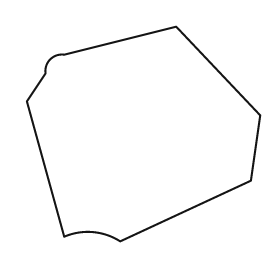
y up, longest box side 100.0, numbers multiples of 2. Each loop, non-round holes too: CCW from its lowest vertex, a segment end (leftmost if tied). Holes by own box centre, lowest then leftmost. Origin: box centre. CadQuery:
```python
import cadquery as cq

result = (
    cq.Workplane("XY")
    .moveTo(-10.0, -46.0)
    .lineTo(46.0, -20.0)
    .lineTo(50.0, 8.0)
    .lineTo(14.0, 46.0)
    .lineTo(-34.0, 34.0)
    .threePointArc((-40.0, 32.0), (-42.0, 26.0))
    .lineTo(-50.0, 14.0)
    .lineTo(-34.0, -44.0)
    .threePointArc((-22.0, -42.0), (-10.0, -46.0))
    .close()
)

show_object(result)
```